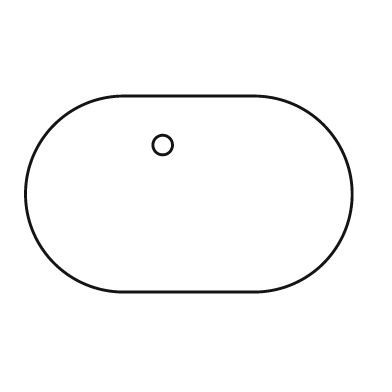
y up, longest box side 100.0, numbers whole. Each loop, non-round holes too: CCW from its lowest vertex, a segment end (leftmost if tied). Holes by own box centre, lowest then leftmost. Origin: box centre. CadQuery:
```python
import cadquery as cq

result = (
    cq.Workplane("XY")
    .moveTo(-20.0, -30.0)
    .lineTo(20.0, -30.0)
    .threePointArc((50.0, 0.0), (20.0, 30.0))
    .lineTo(-20.0, 30.0)
    .threePointArc((-50.0, 0.0), (-20.0, -30.0))
    .close()
    .moveTo(-8.0, 15.0)
    .circle(3.0)
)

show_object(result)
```